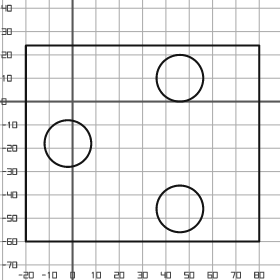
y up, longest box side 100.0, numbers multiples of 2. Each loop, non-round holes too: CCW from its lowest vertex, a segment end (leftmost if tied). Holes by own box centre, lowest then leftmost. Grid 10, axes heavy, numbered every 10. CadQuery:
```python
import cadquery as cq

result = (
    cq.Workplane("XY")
    .moveTo(-20.0, -60.0)
    .lineTo(80.0, -60.0)
    .lineTo(80.0, 24.0)
    .lineTo(-20.0, 24.0)
    .close()
    .moveTo(46.0, -46.0)
    .circle(10.0)
    .moveTo(-2.0, -18.0)
    .circle(10.0)
    .moveTo(46.0, 10.0)
    .circle(10.0)
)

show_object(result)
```